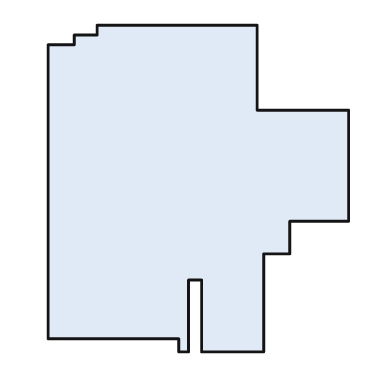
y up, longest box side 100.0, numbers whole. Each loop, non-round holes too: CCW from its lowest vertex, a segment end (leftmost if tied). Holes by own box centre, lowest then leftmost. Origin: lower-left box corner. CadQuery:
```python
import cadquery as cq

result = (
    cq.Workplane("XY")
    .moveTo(40.0, 0.0)
    .lineTo(43.0, 0.0)
    .lineTo(43.0, 22.0)
    .lineTo(47.0, 22.0)
    .lineTo(47.0, 0.0)
    .lineTo(66.0, 0.0)
    .lineTo(66.0, 30.0)
    .lineTo(74.0, 30.0)
    .lineTo(74.0, 40.0)
    .lineTo(92.0, 40.0)
    .lineTo(92.0, 74.0)
    .lineTo(64.0, 74.0)
    .lineTo(64.0, 100.0)
    .lineTo(15.0, 100.0)
    .lineTo(15.0, 97.0)
    .lineTo(8.0, 97.0)
    .lineTo(8.0, 94.0)
    .lineTo(0.0, 94.0)
    .lineTo(0.0, 4.0)
    .lineTo(40.0, 4.0)
    .close()
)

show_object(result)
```